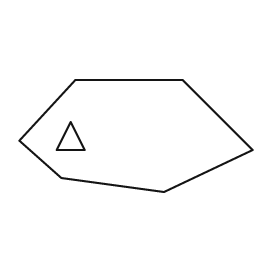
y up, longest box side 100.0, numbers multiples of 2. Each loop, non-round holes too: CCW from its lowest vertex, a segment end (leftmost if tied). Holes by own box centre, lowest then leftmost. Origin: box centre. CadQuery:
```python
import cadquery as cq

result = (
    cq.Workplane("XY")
    .moveTo(12.0, -24.0)
    .lineTo(50.0, -6.0)
    .lineTo(20.0, 24.0)
    .lineTo(-26.0, 24.0)
    .lineTo(-50.0, -2.0)
    .lineTo(-32.0, -18.0)
    .close()
    .moveTo(-34.0, -6.0)
    .lineTo(-22.0, -6.0)
    .lineTo(-28.0, 6.0)
    .close()
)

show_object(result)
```